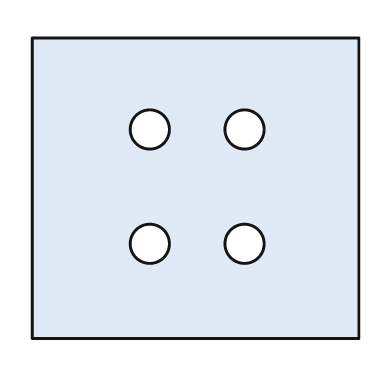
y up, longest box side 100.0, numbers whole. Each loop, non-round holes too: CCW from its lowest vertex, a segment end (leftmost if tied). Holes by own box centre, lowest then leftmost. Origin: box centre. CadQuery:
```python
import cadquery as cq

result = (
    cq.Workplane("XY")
    .moveTo(-50.0, -46.0)
    .lineTo(50.0, -46.0)
    .lineTo(50.0, 46.0)
    .lineTo(-50.0, 46.0)
    .close()
    .moveTo(-14.0, -17.0)
    .circle(6.0)
    .moveTo(15.0, -17.0)
    .circle(6.0)
    .moveTo(-14.0, 18.0)
    .circle(6.0)
    .moveTo(15.0, 18.0)
    .circle(6.0)
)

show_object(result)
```